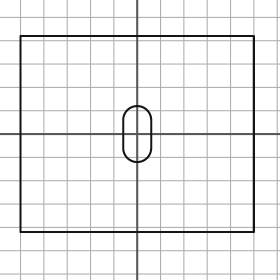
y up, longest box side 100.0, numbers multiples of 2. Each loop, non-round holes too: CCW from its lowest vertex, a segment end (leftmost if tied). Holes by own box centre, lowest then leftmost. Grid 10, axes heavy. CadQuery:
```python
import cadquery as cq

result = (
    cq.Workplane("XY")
    .moveTo(-50.0, -42.0)
    .lineTo(50.0, -42.0)
    .lineTo(50.0, 42.0)
    .lineTo(-50.0, 42.0)
    .close()
    .moveTo(-6.0, -6.0)
    .threePointArc((0.0, -12.0), (6.0, -6.0))
    .lineTo(6.0, 6.0)
    .threePointArc((0.0, 12.0), (-6.0, 6.0))
    .close()
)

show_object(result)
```